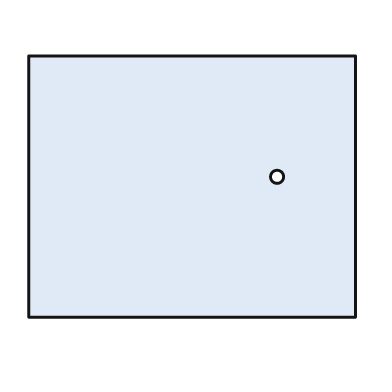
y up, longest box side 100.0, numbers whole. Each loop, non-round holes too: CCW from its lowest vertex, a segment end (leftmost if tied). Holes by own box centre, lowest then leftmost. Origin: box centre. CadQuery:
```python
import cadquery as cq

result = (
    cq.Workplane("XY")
    .moveTo(-50.0, -40.0)
    .lineTo(50.0, -40.0)
    .lineTo(50.0, 40.0)
    .lineTo(-50.0, 40.0)
    .close()
    .moveTo(26.0, 3.0)
    .circle(2.0)
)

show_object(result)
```